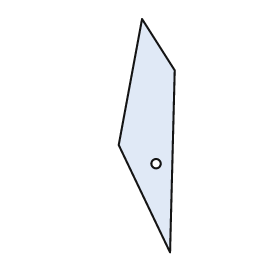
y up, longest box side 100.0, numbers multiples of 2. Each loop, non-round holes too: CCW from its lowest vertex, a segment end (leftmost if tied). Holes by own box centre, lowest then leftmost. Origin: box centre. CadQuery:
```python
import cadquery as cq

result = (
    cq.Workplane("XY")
    .moveTo(10.0, -50.0)
    .lineTo(12.0, 28.0)
    .lineTo(-2.0, 50.0)
    .lineTo(-12.0, -4.0)
    .close()
    .moveTo(4.0, -12.0)
    .circle(2.0)
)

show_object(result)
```